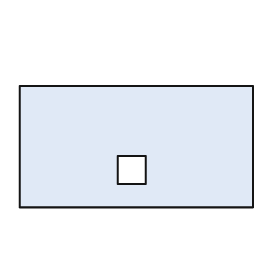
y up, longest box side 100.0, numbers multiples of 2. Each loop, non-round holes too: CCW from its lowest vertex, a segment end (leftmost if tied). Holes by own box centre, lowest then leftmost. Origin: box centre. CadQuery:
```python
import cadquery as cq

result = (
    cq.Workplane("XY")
    .moveTo(-50.0, -26.0)
    .lineTo(50.0, -26.0)
    .lineTo(50.0, 26.0)
    .lineTo(-50.0, 26.0)
    .close()
    .moveTo(-8.0, -16.0)
    .lineTo(4.0, -16.0)
    .lineTo(4.0, -4.0)
    .lineTo(-8.0, -4.0)
    .close()
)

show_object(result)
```